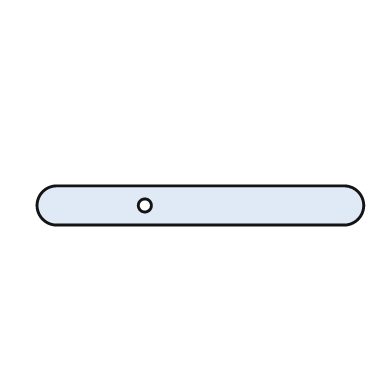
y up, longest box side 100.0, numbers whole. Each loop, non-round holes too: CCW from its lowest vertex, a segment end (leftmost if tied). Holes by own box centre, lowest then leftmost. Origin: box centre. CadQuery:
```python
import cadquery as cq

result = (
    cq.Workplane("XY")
    .moveTo(-44.0, -6.0)
    .lineTo(44.0, -6.0)
    .threePointArc((50.0, 0.0), (44.0, 6.0))
    .lineTo(-44.0, 6.0)
    .threePointArc((-50.0, 0.0), (-44.0, -6.0))
    .close()
    .moveTo(-17.0, 0.0)
    .circle(2.0)
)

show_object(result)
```